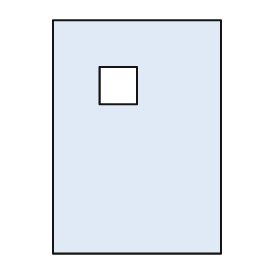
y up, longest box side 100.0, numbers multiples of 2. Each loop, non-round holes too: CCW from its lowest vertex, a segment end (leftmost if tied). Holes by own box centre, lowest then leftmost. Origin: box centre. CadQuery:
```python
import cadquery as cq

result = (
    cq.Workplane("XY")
    .moveTo(-36.0, -50.0)
    .lineTo(36.0, -50.0)
    .lineTo(36.0, 50.0)
    .lineTo(-36.0, 50.0)
    .close()
    .moveTo(-16.0, 14.0)
    .lineTo(0.0, 14.0)
    .lineTo(0.0, 30.0)
    .lineTo(-16.0, 30.0)
    .close()
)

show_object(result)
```